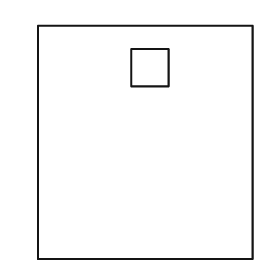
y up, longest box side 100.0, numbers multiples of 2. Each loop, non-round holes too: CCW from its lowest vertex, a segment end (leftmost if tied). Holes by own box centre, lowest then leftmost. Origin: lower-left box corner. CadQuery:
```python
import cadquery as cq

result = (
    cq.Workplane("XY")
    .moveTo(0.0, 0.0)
    .lineTo(92.0, 0.0)
    .lineTo(92.0, 100.0)
    .lineTo(0.0, 100.0)
    .close()
    .moveTo(40.0, 74.0)
    .lineTo(56.0, 74.0)
    .lineTo(56.0, 90.0)
    .lineTo(40.0, 90.0)
    .close()
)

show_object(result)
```